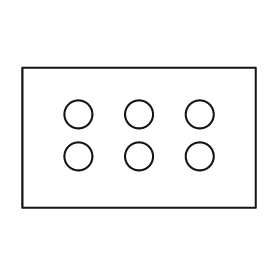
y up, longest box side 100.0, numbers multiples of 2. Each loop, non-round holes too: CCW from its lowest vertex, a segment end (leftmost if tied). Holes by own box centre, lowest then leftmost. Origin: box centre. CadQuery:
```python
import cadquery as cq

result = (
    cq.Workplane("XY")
    .moveTo(-50.0, -30.0)
    .lineTo(50.0, -30.0)
    .lineTo(50.0, 30.0)
    .lineTo(-50.0, 30.0)
    .close()
    .moveTo(-26.0, -8.0)
    .circle(6.0)
    .moveTo(0.0, -8.0)
    .circle(6.0)
    .moveTo(26.0, -8.0)
    .circle(6.0)
    .moveTo(-26.0, 10.0)
    .circle(6.0)
    .moveTo(0.0, 10.0)
    .circle(6.0)
    .moveTo(26.0, 10.0)
    .circle(6.0)
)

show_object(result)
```